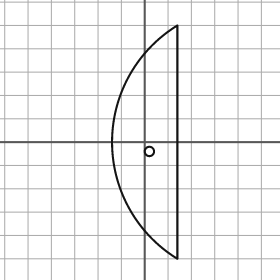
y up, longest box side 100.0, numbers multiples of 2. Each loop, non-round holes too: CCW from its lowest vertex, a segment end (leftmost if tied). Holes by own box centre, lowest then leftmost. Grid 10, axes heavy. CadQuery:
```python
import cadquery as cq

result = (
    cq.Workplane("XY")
    .moveTo(14.0, -50.0)
    .lineTo(14.0, 50.0)
    .threePointArc((-14.0, 0.0), (14.0, -50.0))
    .close()
    .moveTo(2.0, -4.0)
    .circle(2.0)
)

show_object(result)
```